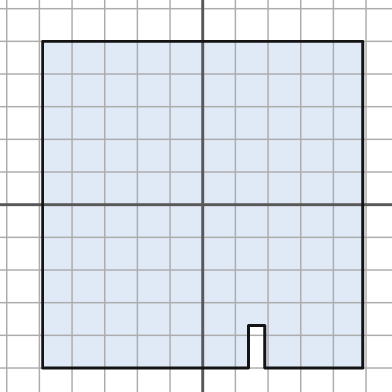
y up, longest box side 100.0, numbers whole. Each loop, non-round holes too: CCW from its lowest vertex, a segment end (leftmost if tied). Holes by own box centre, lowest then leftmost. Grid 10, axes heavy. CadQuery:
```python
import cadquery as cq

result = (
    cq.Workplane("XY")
    .moveTo(-49.0, -50.0)
    .lineTo(14.0, -50.0)
    .lineTo(14.0, -37.0)
    .lineTo(19.0, -37.0)
    .lineTo(19.0, -50.0)
    .lineTo(49.0, -50.0)
    .lineTo(49.0, 50.0)
    .lineTo(-49.0, 50.0)
    .close()
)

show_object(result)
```